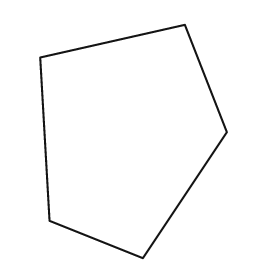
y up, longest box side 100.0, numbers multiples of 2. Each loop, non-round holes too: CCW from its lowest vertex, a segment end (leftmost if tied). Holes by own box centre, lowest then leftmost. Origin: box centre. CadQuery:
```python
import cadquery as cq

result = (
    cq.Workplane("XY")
    .moveTo(4.0, -50.0)
    .lineTo(40.0, 4.0)
    .lineTo(22.0, 50.0)
    .lineTo(-40.0, 36.0)
    .lineTo(-36.0, -34.0)
    .close()
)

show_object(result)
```